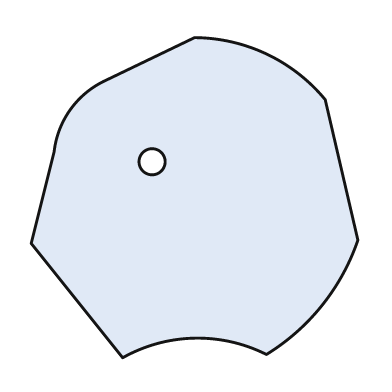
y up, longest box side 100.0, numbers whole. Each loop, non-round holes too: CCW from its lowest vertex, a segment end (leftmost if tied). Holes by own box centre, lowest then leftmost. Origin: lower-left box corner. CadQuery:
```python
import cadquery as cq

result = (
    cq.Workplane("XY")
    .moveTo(28.0, 0.0)
    .threePointArc((50.0, 6.0), (72.0, 1.0))
    .threePointArc((89.0, 16.0), (100.0, 36.0))
    .lineTo(90.0, 79.0)
    .threePointArc((72.0, 93.0), (50.0, 98.0))
    .lineTo(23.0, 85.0)
    .threePointArc((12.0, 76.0), (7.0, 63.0))
    .lineTo(0.0, 35.0)
    .close()
    .moveTo(37.0, 60.0)
    .circle(4.0)
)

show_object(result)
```